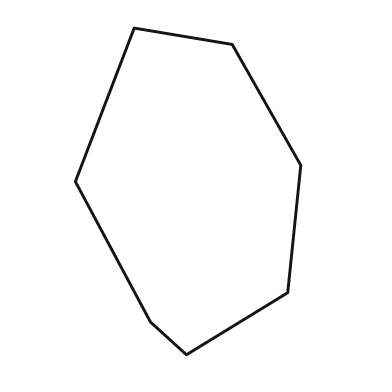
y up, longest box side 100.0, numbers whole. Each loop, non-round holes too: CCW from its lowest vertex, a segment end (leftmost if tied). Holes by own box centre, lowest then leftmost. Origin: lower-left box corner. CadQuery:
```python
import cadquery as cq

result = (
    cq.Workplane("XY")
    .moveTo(34.0, 0.0)
    .lineTo(65.0, 19.0)
    .lineTo(69.0, 58.0)
    .lineTo(48.0, 95.0)
    .lineTo(18.0, 100.0)
    .lineTo(0.0, 53.0)
    .lineTo(23.0, 10.0)
    .close()
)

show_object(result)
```